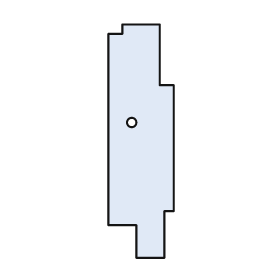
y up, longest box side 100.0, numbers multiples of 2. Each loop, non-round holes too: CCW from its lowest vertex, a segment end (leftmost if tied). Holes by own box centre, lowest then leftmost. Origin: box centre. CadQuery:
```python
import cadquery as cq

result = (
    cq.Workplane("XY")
    .moveTo(-2.0, -50.0)
    .lineTo(10.0, -50.0)
    .lineTo(10.0, -30.0)
    .lineTo(14.0, -30.0)
    .lineTo(14.0, 24.0)
    .lineTo(8.0, 24.0)
    .lineTo(8.0, 50.0)
    .lineTo(-8.0, 50.0)
    .lineTo(-8.0, 46.0)
    .lineTo(-14.0, 46.0)
    .lineTo(-14.0, -36.0)
    .lineTo(-2.0, -36.0)
    .close()
    .moveTo(-4.0, 8.0)
    .circle(2.0)
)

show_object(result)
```